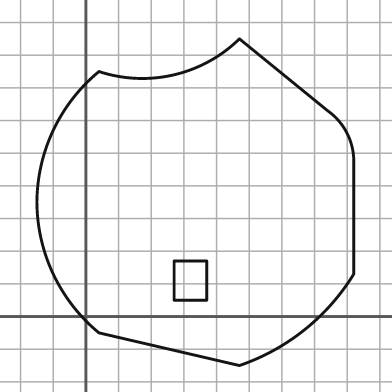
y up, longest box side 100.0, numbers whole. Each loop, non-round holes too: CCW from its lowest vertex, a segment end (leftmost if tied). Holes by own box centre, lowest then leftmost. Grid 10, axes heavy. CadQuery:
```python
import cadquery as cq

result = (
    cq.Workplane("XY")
    .moveTo(47.0, -15.0)
    .threePointArc((67.0, -4.0), (82.0, 13.0))
    .lineTo(82.0, 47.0)
    .threePointArc((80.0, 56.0), (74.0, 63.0))
    .lineTo(47.0, 85.0)
    .threePointArc((27.0, 74.0), (4.0, 75.0))
    .threePointArc((-10.0, 57.0), (-15.0, 35.0))
    .threePointArc((-10.0, 13.0), (4.0, -5.0))
    .close()
    .moveTo(27.0, 5.0)
    .lineTo(37.0, 5.0)
    .lineTo(37.0, 17.0)
    .lineTo(27.0, 17.0)
    .close()
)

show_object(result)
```